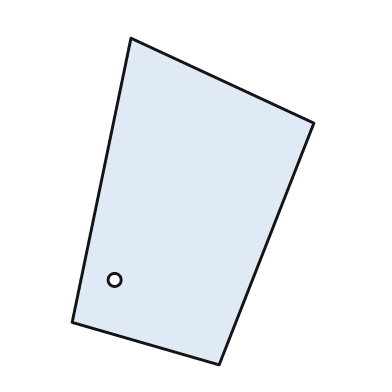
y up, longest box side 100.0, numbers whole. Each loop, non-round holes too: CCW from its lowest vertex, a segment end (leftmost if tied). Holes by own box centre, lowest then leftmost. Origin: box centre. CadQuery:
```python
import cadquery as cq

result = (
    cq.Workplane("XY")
    .moveTo(8.0, -50.0)
    .lineTo(37.0, 24.0)
    .lineTo(-19.0, 50.0)
    .lineTo(-37.0, -37.0)
    .close()
    .moveTo(-24.0, -24.0)
    .circle(2.0)
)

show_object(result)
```